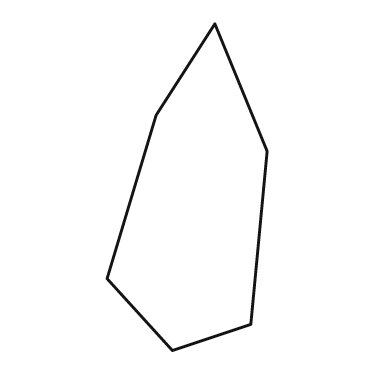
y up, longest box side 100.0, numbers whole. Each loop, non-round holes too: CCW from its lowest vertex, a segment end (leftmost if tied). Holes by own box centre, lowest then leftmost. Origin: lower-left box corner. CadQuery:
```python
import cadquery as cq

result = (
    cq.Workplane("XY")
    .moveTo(20.0, 0.0)
    .lineTo(44.0, 8.0)
    .lineTo(49.0, 61.0)
    .lineTo(33.0, 100.0)
    .lineTo(15.0, 72.0)
    .lineTo(0.0, 22.0)
    .close()
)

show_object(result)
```